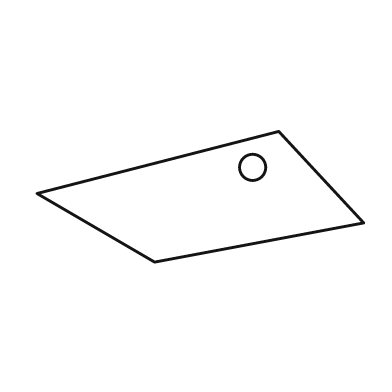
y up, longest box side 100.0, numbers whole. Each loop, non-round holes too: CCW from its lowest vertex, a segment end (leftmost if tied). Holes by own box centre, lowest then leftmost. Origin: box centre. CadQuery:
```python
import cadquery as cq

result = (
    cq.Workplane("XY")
    .moveTo(-14.0, -20.0)
    .lineTo(50.0, -8.0)
    .lineTo(24.0, 20.0)
    .lineTo(-50.0, 1.0)
    .close()
    .moveTo(16.0, 9.0)
    .circle(4.0)
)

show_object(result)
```